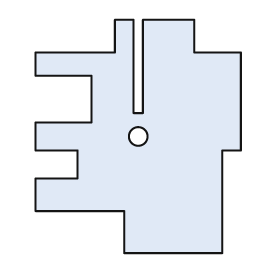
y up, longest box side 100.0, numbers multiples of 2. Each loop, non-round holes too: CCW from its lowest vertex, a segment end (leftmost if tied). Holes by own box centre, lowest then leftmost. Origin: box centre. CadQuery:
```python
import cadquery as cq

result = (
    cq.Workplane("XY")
    .moveTo(-6.0, -50.0)
    .lineTo(36.0, -50.0)
    .lineTo(36.0, -6.0)
    .lineTo(44.0, -6.0)
    .lineTo(44.0, 36.0)
    .lineTo(24.0, 36.0)
    .lineTo(24.0, 50.0)
    .lineTo(2.0, 50.0)
    .lineTo(2.0, 10.0)
    .lineTo(-2.0, 10.0)
    .lineTo(-2.0, 50.0)
    .lineTo(-10.0, 50.0)
    .lineTo(-10.0, 36.0)
    .lineTo(-44.0, 36.0)
    .lineTo(-44.0, 26.0)
    .lineTo(-20.0, 26.0)
    .lineTo(-20.0, 6.0)
    .lineTo(-44.0, 6.0)
    .lineTo(-44.0, -6.0)
    .lineTo(-26.0, -6.0)
    .lineTo(-26.0, -18.0)
    .lineTo(-44.0, -18.0)
    .lineTo(-44.0, -32.0)
    .lineTo(-6.0, -32.0)
    .close()
    .moveTo(0.0, 0.0)
    .circle(4.0)
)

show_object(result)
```